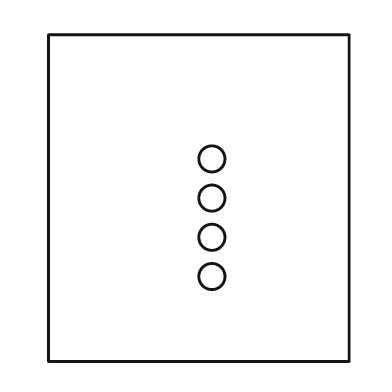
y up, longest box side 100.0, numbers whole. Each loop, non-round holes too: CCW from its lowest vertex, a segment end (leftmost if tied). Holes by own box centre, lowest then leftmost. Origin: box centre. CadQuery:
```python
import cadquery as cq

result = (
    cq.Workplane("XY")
    .moveTo(-46.0, -50.0)
    .lineTo(46.0, -50.0)
    .lineTo(46.0, 50.0)
    .lineTo(-46.0, 50.0)
    .close()
    .moveTo(4.0, -24.0)
    .circle(4.0)
    .moveTo(4.0, -12.0)
    .circle(4.0)
    .moveTo(4.0, 0.0)
    .circle(4.0)
    .moveTo(4.0, 12.0)
    .circle(4.0)
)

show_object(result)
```